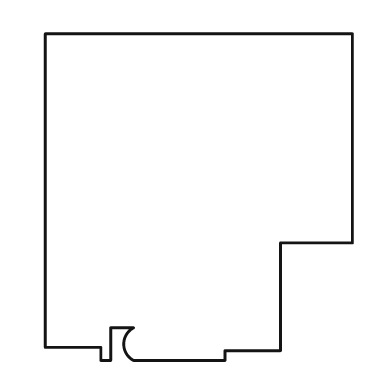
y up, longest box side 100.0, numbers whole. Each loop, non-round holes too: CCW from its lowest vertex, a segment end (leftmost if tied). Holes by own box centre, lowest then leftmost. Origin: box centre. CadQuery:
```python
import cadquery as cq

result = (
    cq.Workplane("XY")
    .moveTo(-30.0, -50.0)
    .lineTo(-27.0, -50.0)
    .lineTo(-27.0, -40.0)
    .lineTo(-20.0, -40.0)
    .threePointArc((-23.0, -45.0), (-20.0, -50.0))
    .lineTo(8.0, -50.0)
    .lineTo(8.0, -47.0)
    .lineTo(25.0, -47.0)
    .lineTo(25.0, -14.0)
    .lineTo(47.0, -14.0)
    .lineTo(47.0, 50.0)
    .lineTo(-47.0, 50.0)
    .lineTo(-47.0, -46.0)
    .lineTo(-30.0, -46.0)
    .close()
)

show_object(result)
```